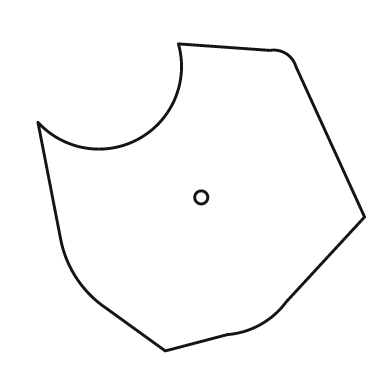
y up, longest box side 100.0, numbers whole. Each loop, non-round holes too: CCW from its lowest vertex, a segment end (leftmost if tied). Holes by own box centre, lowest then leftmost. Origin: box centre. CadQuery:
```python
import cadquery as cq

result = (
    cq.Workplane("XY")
    .moveTo(-11.0, -47.0)
    .lineTo(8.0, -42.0)
    .threePointArc((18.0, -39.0), (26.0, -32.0))
    .lineTo(50.0, -6.0)
    .lineTo(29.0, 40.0)
    .threePointArc((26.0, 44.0), (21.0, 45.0))
    .lineTo(-7.0, 47.0)
    .threePointArc((-19.0, 18.0), (-50.0, 23.0))
    .lineTo(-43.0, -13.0)
    .threePointArc((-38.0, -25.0), (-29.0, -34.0))
    .close()
    .moveTo(0.0, 0.0)
    .circle(2.0)
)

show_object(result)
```